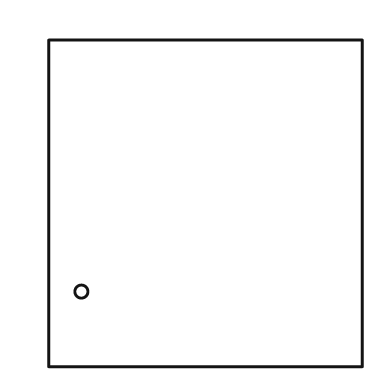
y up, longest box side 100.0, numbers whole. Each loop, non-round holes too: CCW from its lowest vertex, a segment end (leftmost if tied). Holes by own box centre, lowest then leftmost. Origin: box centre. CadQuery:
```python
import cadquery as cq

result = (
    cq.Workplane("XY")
    .moveTo(-48.0, -50.0)
    .lineTo(48.0, -50.0)
    .lineTo(48.0, 50.0)
    .lineTo(-48.0, 50.0)
    .close()
    .moveTo(-38.0, -27.0)
    .circle(2.0)
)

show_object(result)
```